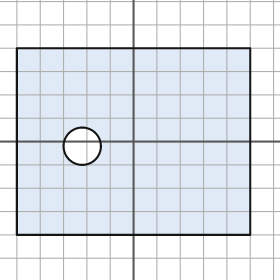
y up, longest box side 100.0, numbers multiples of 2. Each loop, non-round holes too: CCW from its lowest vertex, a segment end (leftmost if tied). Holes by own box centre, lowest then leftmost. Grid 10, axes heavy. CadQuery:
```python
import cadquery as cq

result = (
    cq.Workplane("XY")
    .moveTo(-50.0, -40.0)
    .lineTo(50.0, -40.0)
    .lineTo(50.0, 40.0)
    .lineTo(-50.0, 40.0)
    .close()
    .moveTo(-22.0, -2.0)
    .circle(8.0)
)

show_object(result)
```